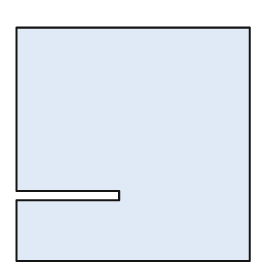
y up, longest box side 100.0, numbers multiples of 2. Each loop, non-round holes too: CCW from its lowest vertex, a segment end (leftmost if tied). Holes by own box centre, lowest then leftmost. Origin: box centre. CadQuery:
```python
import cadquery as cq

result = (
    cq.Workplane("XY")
    .moveTo(-50.0, -50.0)
    .lineTo(50.0, -50.0)
    .lineTo(50.0, 50.0)
    .lineTo(-50.0, 50.0)
    .lineTo(-50.0, -20.0)
    .lineTo(-6.0, -20.0)
    .lineTo(-6.0, -24.0)
    .lineTo(-50.0, -24.0)
    .close()
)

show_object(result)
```